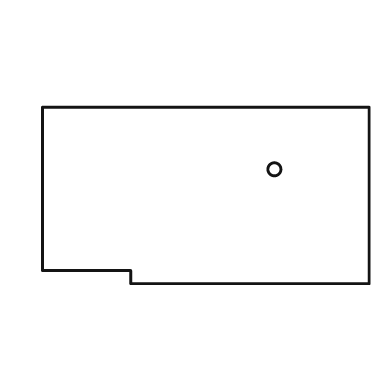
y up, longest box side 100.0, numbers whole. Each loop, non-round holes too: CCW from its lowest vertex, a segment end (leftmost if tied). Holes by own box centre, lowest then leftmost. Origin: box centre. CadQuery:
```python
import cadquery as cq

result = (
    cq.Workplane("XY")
    .moveTo(-23.0, -27.0)
    .lineTo(50.0, -27.0)
    .lineTo(50.0, 27.0)
    .lineTo(-50.0, 27.0)
    .lineTo(-50.0, -23.0)
    .lineTo(-23.0, -23.0)
    .close()
    .moveTo(21.0, 8.0)
    .circle(2.0)
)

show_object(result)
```